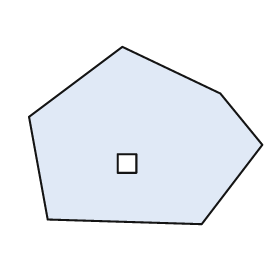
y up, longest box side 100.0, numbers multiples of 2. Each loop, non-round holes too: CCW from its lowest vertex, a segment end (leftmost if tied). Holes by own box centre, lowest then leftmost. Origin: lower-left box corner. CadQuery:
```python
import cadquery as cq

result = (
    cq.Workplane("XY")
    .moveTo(74.0, 0.0)
    .lineTo(100.0, 34.0)
    .lineTo(82.0, 56.0)
    .lineTo(40.0, 76.0)
    .lineTo(0.0, 46.0)
    .lineTo(8.0, 2.0)
    .close()
    .moveTo(38.0, 22.0)
    .lineTo(46.0, 22.0)
    .lineTo(46.0, 30.0)
    .lineTo(38.0, 30.0)
    .close()
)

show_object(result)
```